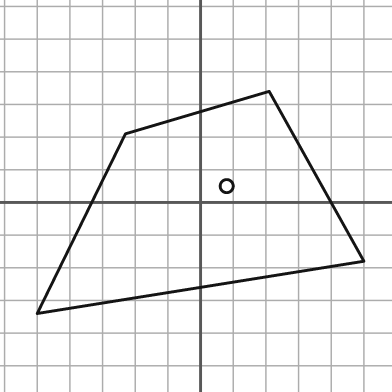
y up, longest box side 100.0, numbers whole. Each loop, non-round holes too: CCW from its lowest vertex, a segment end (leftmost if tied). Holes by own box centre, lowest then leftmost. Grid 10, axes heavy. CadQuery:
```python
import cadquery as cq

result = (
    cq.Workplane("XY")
    .moveTo(-50.0, -34.0)
    .lineTo(50.0, -18.0)
    .lineTo(21.0, 34.0)
    .lineTo(-23.0, 21.0)
    .close()
    .moveTo(8.0, 5.0)
    .circle(2.0)
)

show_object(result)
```